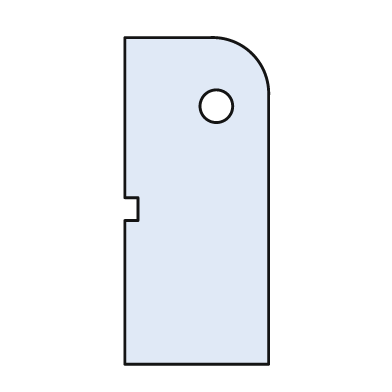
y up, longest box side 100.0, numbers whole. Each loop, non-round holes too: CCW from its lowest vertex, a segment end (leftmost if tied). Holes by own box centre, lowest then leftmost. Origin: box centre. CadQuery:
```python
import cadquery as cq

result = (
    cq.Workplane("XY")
    .moveTo(-22.0, -50.0)
    .lineTo(22.0, -50.0)
    .lineTo(22.0, 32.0)
    .threePointArc((17.0, 45.0), (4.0, 50.0))
    .lineTo(-22.0, 50.0)
    .lineTo(-22.0, 1.0)
    .lineTo(-18.0, 1.0)
    .lineTo(-18.0, -6.0)
    .lineTo(-22.0, -6.0)
    .close()
    .moveTo(6.0, 29.0)
    .circle(5.0)
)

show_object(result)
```